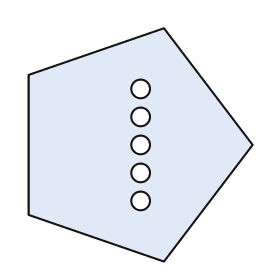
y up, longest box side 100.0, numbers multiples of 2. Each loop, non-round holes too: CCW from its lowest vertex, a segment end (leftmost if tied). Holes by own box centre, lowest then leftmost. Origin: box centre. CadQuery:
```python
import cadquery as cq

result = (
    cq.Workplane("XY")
    .moveTo(10.0, -50.0)
    .lineTo(48.0, 0.0)
    .lineTo(10.0, 50.0)
    .lineTo(-48.0, 30.0)
    .lineTo(-48.0, -30.0)
    .close()
    .moveTo(0.0, -24.0)
    .circle(4.0)
    .moveTo(0.0, -12.0)
    .circle(4.0)
    .moveTo(0.0, 0.0)
    .circle(4.0)
    .moveTo(0.0, 12.0)
    .circle(4.0)
    .moveTo(0.0, 24.0)
    .circle(4.0)
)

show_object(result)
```